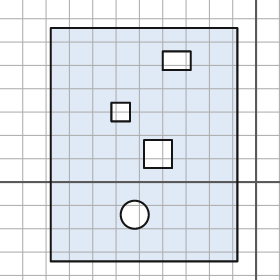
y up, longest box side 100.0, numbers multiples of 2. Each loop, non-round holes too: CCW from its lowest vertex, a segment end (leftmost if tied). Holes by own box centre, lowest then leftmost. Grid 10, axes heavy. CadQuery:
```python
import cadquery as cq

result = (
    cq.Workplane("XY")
    .moveTo(-88.0, -34.0)
    .lineTo(-8.0, -34.0)
    .lineTo(-8.0, 66.0)
    .lineTo(-88.0, 66.0)
    .close()
    .moveTo(-52.0, -14.0)
    .circle(6.0)
    .moveTo(-48.0, 6.0)
    .lineTo(-36.0, 6.0)
    .lineTo(-36.0, 18.0)
    .lineTo(-48.0, 18.0)
    .close()
    .moveTo(-62.0, 26.0)
    .lineTo(-54.0, 26.0)
    .lineTo(-54.0, 34.0)
    .lineTo(-62.0, 34.0)
    .close()
    .moveTo(-40.0, 48.0)
    .lineTo(-28.0, 48.0)
    .lineTo(-28.0, 56.0)
    .lineTo(-40.0, 56.0)
    .close()
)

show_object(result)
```